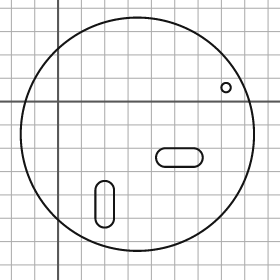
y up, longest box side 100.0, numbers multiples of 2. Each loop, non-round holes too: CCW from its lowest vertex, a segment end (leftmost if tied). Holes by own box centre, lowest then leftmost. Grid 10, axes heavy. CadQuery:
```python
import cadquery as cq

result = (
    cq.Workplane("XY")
    .moveTo(34.0, -14.0)
    .circle(50.0)
    .moveTo(16.0, -50.0)
    .threePointArc((20.0, -54.0), (24.0, -50.0))
    .lineTo(24.0, -38.0)
    .threePointArc((20.0, -34.0), (16.0, -38.0))
    .close()
    .moveTo(46.0, -28.0)
    .lineTo(58.0, -28.0)
    .threePointArc((62.0, -24.0), (58.0, -20.0))
    .lineTo(46.0, -20.0)
    .threePointArc((42.0, -24.0), (46.0, -28.0))
    .close()
    .moveTo(72.0, 6.0)
    .circle(2.0)
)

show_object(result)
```